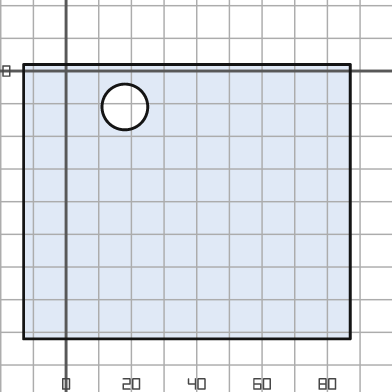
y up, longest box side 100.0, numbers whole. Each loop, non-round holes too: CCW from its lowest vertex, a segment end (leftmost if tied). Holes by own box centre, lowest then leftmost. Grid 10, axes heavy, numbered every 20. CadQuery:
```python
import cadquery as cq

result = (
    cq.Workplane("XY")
    .moveTo(-13.0, -82.0)
    .lineTo(87.0, -82.0)
    .lineTo(87.0, 2.0)
    .lineTo(-13.0, 2.0)
    .close()
    .moveTo(18.0, -11.0)
    .circle(7.0)
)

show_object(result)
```